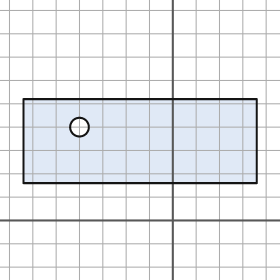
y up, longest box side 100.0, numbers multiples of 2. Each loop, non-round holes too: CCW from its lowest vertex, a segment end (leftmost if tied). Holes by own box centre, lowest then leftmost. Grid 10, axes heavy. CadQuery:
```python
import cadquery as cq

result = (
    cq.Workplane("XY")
    .moveTo(-64.0, 16.0)
    .lineTo(36.0, 16.0)
    .lineTo(36.0, 52.0)
    .lineTo(-64.0, 52.0)
    .close()
    .moveTo(-40.0, 40.0)
    .circle(4.0)
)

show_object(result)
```